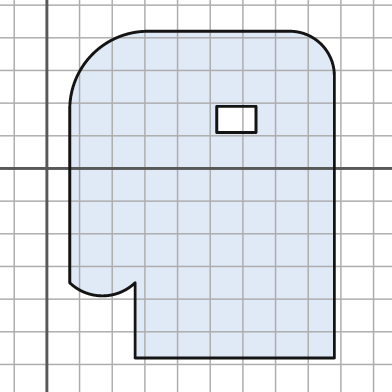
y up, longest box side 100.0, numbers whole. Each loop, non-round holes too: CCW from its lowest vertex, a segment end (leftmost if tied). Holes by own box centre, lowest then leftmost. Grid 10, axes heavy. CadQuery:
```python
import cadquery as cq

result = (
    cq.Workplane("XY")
    .moveTo(27.0, -58.0)
    .lineTo(88.0, -58.0)
    .lineTo(88.0, 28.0)
    .threePointArc((84.0, 38.0), (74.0, 42.0))
    .lineTo(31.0, 42.0)
    .threePointArc((14.0, 35.0), (7.0, 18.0))
    .lineTo(7.0, -35.0)
    .threePointArc((17.0, -39.0), (27.0, -35.0))
    .close()
    .moveTo(52.0, 11.0)
    .lineTo(64.0, 11.0)
    .lineTo(64.0, 19.0)
    .lineTo(52.0, 19.0)
    .close()
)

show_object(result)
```